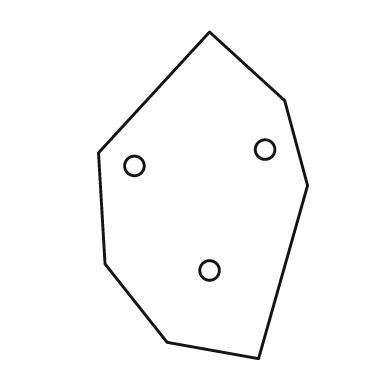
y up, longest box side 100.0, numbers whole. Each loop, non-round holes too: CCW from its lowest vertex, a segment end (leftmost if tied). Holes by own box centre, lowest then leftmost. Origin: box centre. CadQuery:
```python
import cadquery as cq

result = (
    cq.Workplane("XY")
    .moveTo(17.0, -50.0)
    .lineTo(32.0, 3.0)
    .lineTo(25.0, 29.0)
    .lineTo(2.0, 50.0)
    .lineTo(-32.0, 13.0)
    .lineTo(-30.0, -21.0)
    .lineTo(-11.0, -45.0)
    .close()
    .moveTo(2.0, -23.0)
    .circle(3.0)
    .moveTo(-21.0, 9.0)
    .circle(3.0)
    .moveTo(19.0, 14.0)
    .circle(3.0)
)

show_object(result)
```